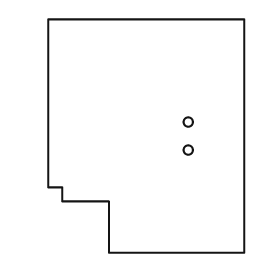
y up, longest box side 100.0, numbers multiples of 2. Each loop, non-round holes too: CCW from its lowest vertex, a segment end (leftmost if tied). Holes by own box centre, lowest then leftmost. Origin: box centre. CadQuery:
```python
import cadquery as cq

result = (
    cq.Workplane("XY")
    .moveTo(-16.0, -50.0)
    .lineTo(42.0, -50.0)
    .lineTo(42.0, 50.0)
    .lineTo(-42.0, 50.0)
    .lineTo(-42.0, -22.0)
    .lineTo(-36.0, -22.0)
    .lineTo(-36.0, -28.0)
    .lineTo(-16.0, -28.0)
    .close()
    .moveTo(18.0, -6.0)
    .circle(2.0)
    .moveTo(18.0, 6.0)
    .circle(2.0)
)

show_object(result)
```